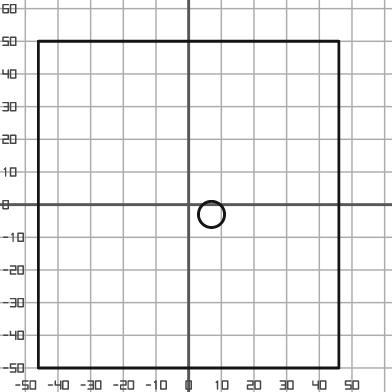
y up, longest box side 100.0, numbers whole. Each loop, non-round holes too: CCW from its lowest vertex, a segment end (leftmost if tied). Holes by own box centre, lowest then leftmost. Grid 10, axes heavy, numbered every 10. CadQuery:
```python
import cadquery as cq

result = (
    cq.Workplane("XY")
    .moveTo(-46.0, -50.0)
    .lineTo(46.0, -50.0)
    .lineTo(46.0, 50.0)
    .lineTo(-46.0, 50.0)
    .close()
    .moveTo(7.0, -3.0)
    .circle(4.0)
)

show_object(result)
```